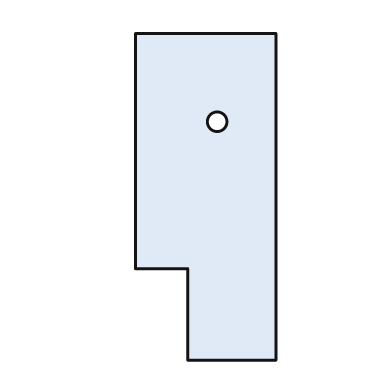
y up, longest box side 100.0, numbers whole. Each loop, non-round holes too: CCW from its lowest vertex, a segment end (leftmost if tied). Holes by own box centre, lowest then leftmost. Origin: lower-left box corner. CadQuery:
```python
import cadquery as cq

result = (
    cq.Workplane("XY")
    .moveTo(16.0, 0.0)
    .lineTo(43.0, 0.0)
    .lineTo(43.0, 100.0)
    .lineTo(0.0, 100.0)
    .lineTo(0.0, 28.0)
    .lineTo(16.0, 28.0)
    .close()
    .moveTo(25.0, 73.0)
    .circle(3.0)
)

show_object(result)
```